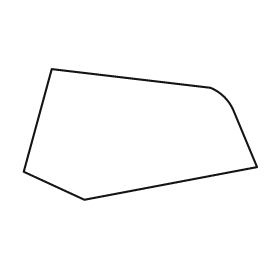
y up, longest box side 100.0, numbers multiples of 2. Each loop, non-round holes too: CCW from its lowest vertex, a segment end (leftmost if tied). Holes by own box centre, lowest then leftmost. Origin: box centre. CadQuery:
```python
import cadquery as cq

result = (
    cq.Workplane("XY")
    .moveTo(-24.0, -28.0)
    .lineTo(50.0, -14.0)
    .lineTo(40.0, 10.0)
    .threePointArc((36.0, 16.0), (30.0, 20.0))
    .lineTo(-38.0, 28.0)
    .lineTo(-50.0, -16.0)
    .close()
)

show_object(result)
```